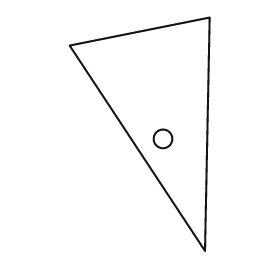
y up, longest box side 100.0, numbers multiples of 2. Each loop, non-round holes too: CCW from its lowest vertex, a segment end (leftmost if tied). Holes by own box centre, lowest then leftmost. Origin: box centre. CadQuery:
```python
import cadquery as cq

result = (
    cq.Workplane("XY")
    .moveTo(28.0, -50.0)
    .lineTo(30.0, 50.0)
    .lineTo(-30.0, 38.0)
    .close()
    .moveTo(10.0, -2.0)
    .circle(4.0)
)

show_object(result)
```